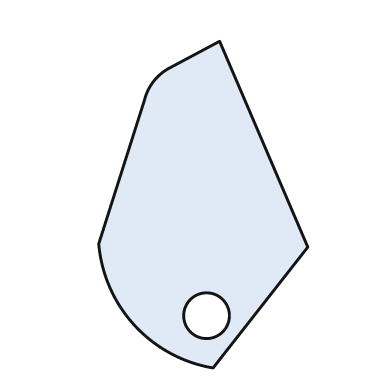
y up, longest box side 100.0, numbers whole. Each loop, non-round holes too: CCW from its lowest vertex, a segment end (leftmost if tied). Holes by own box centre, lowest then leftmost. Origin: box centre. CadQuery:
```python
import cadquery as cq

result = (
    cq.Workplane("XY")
    .moveTo(3.0, -50.0)
    .lineTo(32.0, -13.0)
    .lineTo(5.0, 50.0)
    .lineTo(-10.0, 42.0)
    .threePointArc((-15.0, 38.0), (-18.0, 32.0))
    .lineTo(-32.0, -12.0)
    .threePointArc((-21.0, -37.0), (3.0, -50.0))
    .close()
    .moveTo(1.0, -34.0)
    .circle(7.0)
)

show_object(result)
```